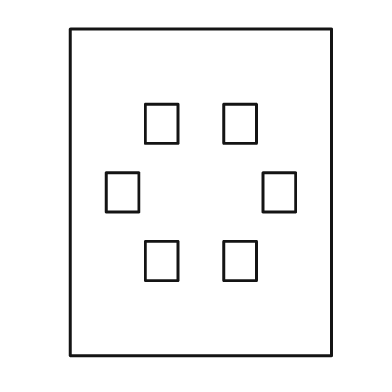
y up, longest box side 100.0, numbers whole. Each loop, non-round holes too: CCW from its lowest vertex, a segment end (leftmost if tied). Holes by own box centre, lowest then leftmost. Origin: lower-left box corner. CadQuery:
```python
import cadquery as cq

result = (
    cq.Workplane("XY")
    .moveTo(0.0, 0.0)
    .lineTo(80.0, 0.0)
    .lineTo(80.0, 100.0)
    .lineTo(0.0, 100.0)
    .close()
    .moveTo(23.0, 23.0)
    .lineTo(33.0, 23.0)
    .lineTo(33.0, 35.0)
    .lineTo(23.0, 35.0)
    .close()
    .moveTo(47.0, 23.0)
    .lineTo(57.0, 23.0)
    .lineTo(57.0, 35.0)
    .lineTo(47.0, 35.0)
    .close()
    .moveTo(11.0, 44.0)
    .lineTo(21.0, 44.0)
    .lineTo(21.0, 56.0)
    .lineTo(11.0, 56.0)
    .close()
    .moveTo(59.0, 44.0)
    .lineTo(69.0, 44.0)
    .lineTo(69.0, 56.0)
    .lineTo(59.0, 56.0)
    .close()
    .moveTo(23.0, 65.0)
    .lineTo(33.0, 65.0)
    .lineTo(33.0, 77.0)
    .lineTo(23.0, 77.0)
    .close()
    .moveTo(47.0, 65.0)
    .lineTo(57.0, 65.0)
    .lineTo(57.0, 77.0)
    .lineTo(47.0, 77.0)
    .close()
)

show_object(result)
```